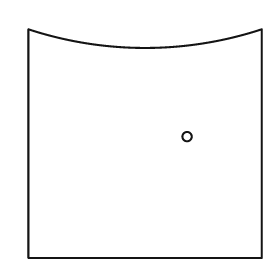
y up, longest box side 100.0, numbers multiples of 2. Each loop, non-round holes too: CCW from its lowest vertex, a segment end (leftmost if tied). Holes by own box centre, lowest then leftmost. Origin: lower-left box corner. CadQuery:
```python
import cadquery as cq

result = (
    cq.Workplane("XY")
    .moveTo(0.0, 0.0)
    .lineTo(100.0, 0.0)
    .lineTo(100.0, 98.0)
    .threePointArc((50.0, 90.0), (0.0, 98.0))
    .close()
    .moveTo(68.0, 52.0)
    .circle(2.0)
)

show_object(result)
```